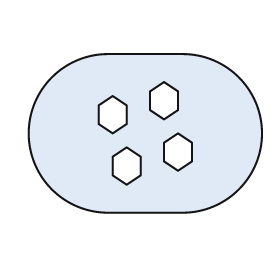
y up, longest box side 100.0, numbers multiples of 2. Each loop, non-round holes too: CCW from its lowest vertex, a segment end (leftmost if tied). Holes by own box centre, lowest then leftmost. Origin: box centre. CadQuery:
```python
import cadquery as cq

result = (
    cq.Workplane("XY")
    .moveTo(-16.0, -34.0)
    .lineTo(16.0, -34.0)
    .threePointArc((50.0, 0.0), (16.0, 34.0))
    .lineTo(-16.0, 34.0)
    .threePointArc((-50.0, 0.0), (-16.0, -34.0))
    .close()
    .moveTo(-8.0, -22.0)
    .lineTo(-2.0, -18.0)
    .lineTo(-2.0, -10.0)
    .lineTo(-8.0, -6.0)
    .lineTo(-14.0, -10.0)
    .lineTo(-14.0, -18.0)
    .close()
    .moveTo(14.0, -16.0)
    .lineTo(20.0, -12.0)
    .lineTo(20.0, -4.0)
    .lineTo(14.0, 0.0)
    .lineTo(8.0, -4.0)
    .lineTo(8.0, -12.0)
    .close()
    .moveTo(-14.0, 0.0)
    .lineTo(-8.0, 4.0)
    .lineTo(-8.0, 12.0)
    .lineTo(-14.0, 16.0)
    .lineTo(-20.0, 12.0)
    .lineTo(-20.0, 4.0)
    .close()
    .moveTo(8.0, 6.0)
    .lineTo(14.0, 10.0)
    .lineTo(14.0, 18.0)
    .lineTo(8.0, 22.0)
    .lineTo(2.0, 18.0)
    .lineTo(2.0, 10.0)
    .close()
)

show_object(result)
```